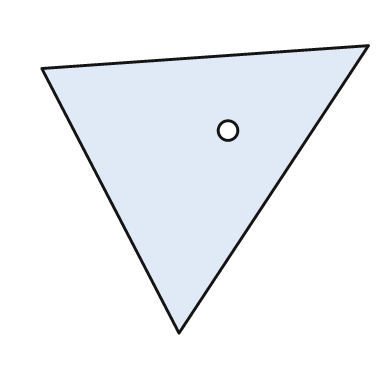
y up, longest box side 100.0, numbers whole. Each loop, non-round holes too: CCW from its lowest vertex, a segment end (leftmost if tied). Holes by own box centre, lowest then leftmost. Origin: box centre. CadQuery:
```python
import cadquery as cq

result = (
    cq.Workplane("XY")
    .moveTo(-8.0, -44.0)
    .lineTo(50.0, 44.0)
    .lineTo(-50.0, 37.0)
    .close()
    .moveTo(7.0, 18.0)
    .circle(3.0)
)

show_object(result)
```